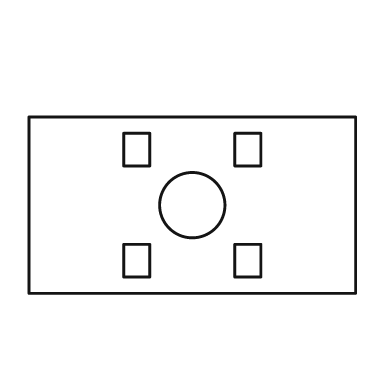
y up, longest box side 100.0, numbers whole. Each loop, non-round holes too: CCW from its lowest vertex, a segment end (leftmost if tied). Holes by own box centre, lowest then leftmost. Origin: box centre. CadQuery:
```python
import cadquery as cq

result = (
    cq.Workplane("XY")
    .moveTo(-50.0, -27.0)
    .lineTo(50.0, -27.0)
    .lineTo(50.0, 27.0)
    .lineTo(-50.0, 27.0)
    .close()
    .moveTo(-21.0, -22.0)
    .lineTo(-13.0, -22.0)
    .lineTo(-13.0, -12.0)
    .lineTo(-21.0, -12.0)
    .close()
    .moveTo(13.0, -22.0)
    .lineTo(21.0, -22.0)
    .lineTo(21.0, -12.0)
    .lineTo(13.0, -12.0)
    .close()
    .moveTo(0.0, 0.0)
    .circle(10.0)
    .moveTo(-21.0, 12.0)
    .lineTo(-13.0, 12.0)
    .lineTo(-13.0, 22.0)
    .lineTo(-21.0, 22.0)
    .close()
    .moveTo(13.0, 12.0)
    .lineTo(21.0, 12.0)
    .lineTo(21.0, 22.0)
    .lineTo(13.0, 22.0)
    .close()
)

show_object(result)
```